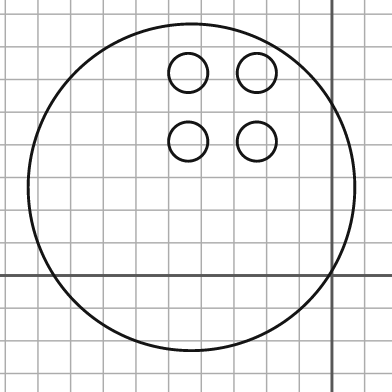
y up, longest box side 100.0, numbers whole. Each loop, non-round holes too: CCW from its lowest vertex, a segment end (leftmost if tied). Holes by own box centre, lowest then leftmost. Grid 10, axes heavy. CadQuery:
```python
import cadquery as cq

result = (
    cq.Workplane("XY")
    .moveTo(-43.0, 27.0)
    .circle(50.0)
    .moveTo(-44.0, 41.0)
    .circle(6.0)
    .moveTo(-23.0, 41.0)
    .circle(6.0)
    .moveTo(-44.0, 62.0)
    .circle(6.0)
    .moveTo(-23.0, 62.0)
    .circle(6.0)
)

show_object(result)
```